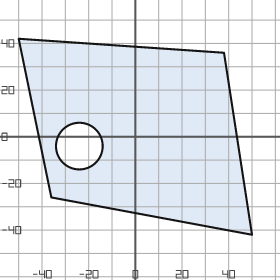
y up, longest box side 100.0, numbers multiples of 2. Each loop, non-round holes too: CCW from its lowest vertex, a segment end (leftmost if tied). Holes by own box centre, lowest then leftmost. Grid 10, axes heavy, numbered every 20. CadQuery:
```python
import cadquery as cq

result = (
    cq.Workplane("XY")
    .moveTo(50.0, -42.0)
    .lineTo(38.0, 36.0)
    .lineTo(-50.0, 42.0)
    .lineTo(-36.0, -26.0)
    .close()
    .moveTo(-24.0, -4.0)
    .circle(10.0)
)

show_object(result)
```